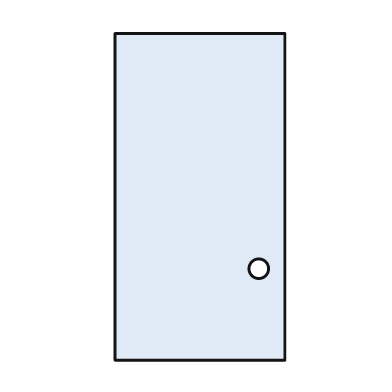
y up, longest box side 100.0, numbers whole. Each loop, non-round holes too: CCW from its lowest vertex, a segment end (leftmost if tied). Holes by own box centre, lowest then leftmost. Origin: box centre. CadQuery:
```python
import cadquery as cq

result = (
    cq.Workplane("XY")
    .moveTo(-26.0, -50.0)
    .lineTo(26.0, -50.0)
    .lineTo(26.0, 50.0)
    .lineTo(-26.0, 50.0)
    .close()
    .moveTo(18.0, -22.0)
    .circle(3.0)
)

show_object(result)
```